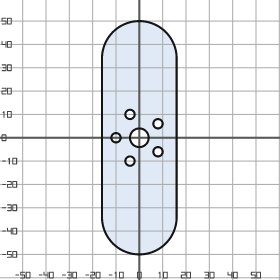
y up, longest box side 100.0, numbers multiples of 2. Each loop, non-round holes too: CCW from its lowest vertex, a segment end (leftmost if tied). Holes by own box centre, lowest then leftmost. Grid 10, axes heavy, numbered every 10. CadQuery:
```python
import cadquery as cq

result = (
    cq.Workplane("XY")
    .moveTo(-16.0, -34.0)
    .threePointArc((0.0, -50.0), (16.0, -34.0))
    .lineTo(16.0, 34.0)
    .threePointArc((0.0, 50.0), (-16.0, 34.0))
    .close()
    .moveTo(-4.0, -10.0)
    .circle(2.0)
    .moveTo(8.0, -6.0)
    .circle(2.0)
    .moveTo(-10.0, 0.0)
    .circle(2.0)
    .moveTo(0.0, 0.0)
    .circle(4.0)
    .moveTo(8.0, 6.0)
    .circle(2.0)
    .moveTo(-4.0, 10.0)
    .circle(2.0)
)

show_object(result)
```